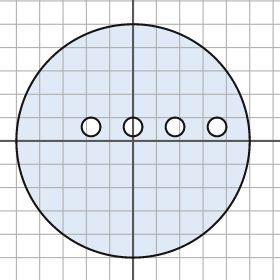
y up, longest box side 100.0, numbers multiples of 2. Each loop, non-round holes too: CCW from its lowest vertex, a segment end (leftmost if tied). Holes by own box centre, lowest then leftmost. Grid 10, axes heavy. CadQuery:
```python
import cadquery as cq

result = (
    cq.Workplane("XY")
    .moveTo(0.0, 0.0)
    .circle(50.0)
    .moveTo(-18.0, 6.0)
    .circle(4.0)
    .moveTo(0.0, 6.0)
    .circle(4.0)
    .moveTo(18.0, 6.0)
    .circle(4.0)
    .moveTo(36.0, 6.0)
    .circle(4.0)
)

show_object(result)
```